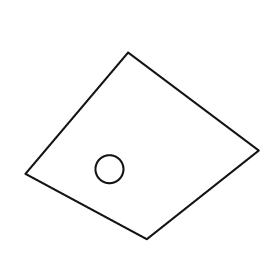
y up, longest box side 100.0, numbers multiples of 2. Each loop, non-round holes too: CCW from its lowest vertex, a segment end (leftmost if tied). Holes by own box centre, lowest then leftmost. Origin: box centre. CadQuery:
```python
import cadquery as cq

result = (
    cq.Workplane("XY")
    .moveTo(2.0, -40.0)
    .lineTo(50.0, -2.0)
    .lineTo(-6.0, 40.0)
    .lineTo(-50.0, -12.0)
    .close()
    .moveTo(-14.0, -10.0)
    .circle(6.0)
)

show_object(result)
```